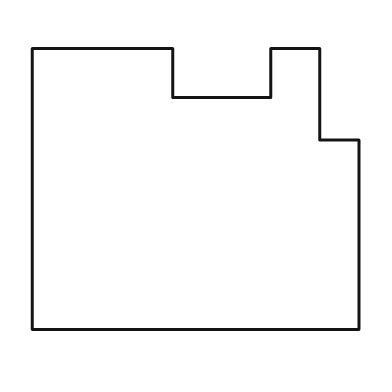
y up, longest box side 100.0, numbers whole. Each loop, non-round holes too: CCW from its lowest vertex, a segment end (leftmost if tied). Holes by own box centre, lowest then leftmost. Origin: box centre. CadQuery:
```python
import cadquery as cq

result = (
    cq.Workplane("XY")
    .moveTo(-50.0, -43.0)
    .lineTo(50.0, -43.0)
    .lineTo(50.0, 15.0)
    .lineTo(38.0, 15.0)
    .lineTo(38.0, 43.0)
    .lineTo(23.0, 43.0)
    .lineTo(23.0, 28.0)
    .lineTo(-7.0, 28.0)
    .lineTo(-7.0, 43.0)
    .lineTo(-50.0, 43.0)
    .close()
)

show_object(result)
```